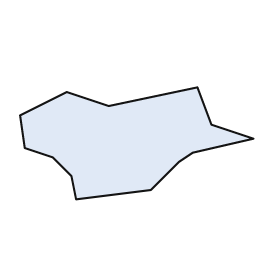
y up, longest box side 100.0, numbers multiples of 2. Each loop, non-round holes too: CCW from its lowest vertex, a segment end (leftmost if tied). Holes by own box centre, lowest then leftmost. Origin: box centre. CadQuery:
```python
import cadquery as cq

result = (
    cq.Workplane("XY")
    .moveTo(-26.0, -24.0)
    .lineTo(6.0, -20.0)
    .lineTo(18.0, -8.0)
    .lineTo(24.0, -4.0)
    .lineTo(50.0, 2.0)
    .lineTo(32.0, 8.0)
    .lineTo(26.0, 24.0)
    .lineTo(-12.0, 16.0)
    .lineTo(-30.0, 22.0)
    .lineTo(-50.0, 12.0)
    .lineTo(-48.0, -2.0)
    .lineTo(-36.0, -6.0)
    .lineTo(-28.0, -14.0)
    .close()
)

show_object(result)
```